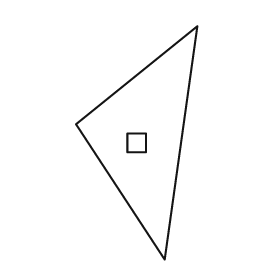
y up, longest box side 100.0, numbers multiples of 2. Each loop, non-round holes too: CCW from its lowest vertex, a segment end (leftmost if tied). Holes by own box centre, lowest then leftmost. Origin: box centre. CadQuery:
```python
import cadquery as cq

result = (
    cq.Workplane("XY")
    .moveTo(12.0, -50.0)
    .lineTo(26.0, 50.0)
    .lineTo(-26.0, 8.0)
    .close()
    .moveTo(-4.0, -4.0)
    .lineTo(4.0, -4.0)
    .lineTo(4.0, 4.0)
    .lineTo(-4.0, 4.0)
    .close()
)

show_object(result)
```